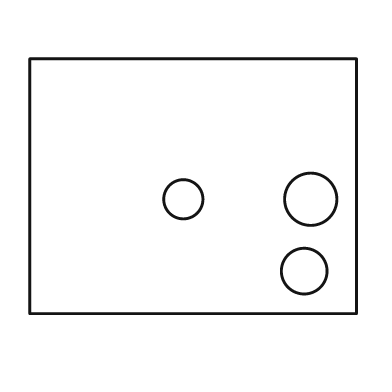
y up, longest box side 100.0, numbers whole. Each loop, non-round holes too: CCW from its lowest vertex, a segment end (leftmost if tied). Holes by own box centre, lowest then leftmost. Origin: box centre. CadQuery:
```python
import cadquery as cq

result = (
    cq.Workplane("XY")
    .moveTo(-50.0, -39.0)
    .lineTo(50.0, -39.0)
    .lineTo(50.0, 39.0)
    .lineTo(-50.0, 39.0)
    .close()
    .moveTo(34.0, -26.0)
    .circle(7.0)
    .moveTo(-3.0, -4.0)
    .circle(6.0)
    .moveTo(36.0, -4.0)
    .circle(8.0)
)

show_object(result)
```